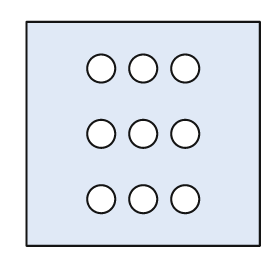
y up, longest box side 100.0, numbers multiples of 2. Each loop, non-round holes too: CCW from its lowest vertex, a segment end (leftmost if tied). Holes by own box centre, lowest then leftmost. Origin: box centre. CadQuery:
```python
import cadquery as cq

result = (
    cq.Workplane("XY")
    .moveTo(-50.0, -48.0)
    .lineTo(50.0, -48.0)
    .lineTo(50.0, 48.0)
    .lineTo(-50.0, 48.0)
    .close()
    .moveTo(-18.0, -28.0)
    .circle(6.0)
    .moveTo(0.0, -28.0)
    .circle(6.0)
    .moveTo(18.0, -28.0)
    .circle(6.0)
    .moveTo(-18.0, 0.0)
    .circle(6.0)
    .moveTo(0.0, 0.0)
    .circle(6.0)
    .moveTo(18.0, 0.0)
    .circle(6.0)
    .moveTo(-18.0, 28.0)
    .circle(6.0)
    .moveTo(0.0, 28.0)
    .circle(6.0)
    .moveTo(18.0, 28.0)
    .circle(6.0)
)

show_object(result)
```